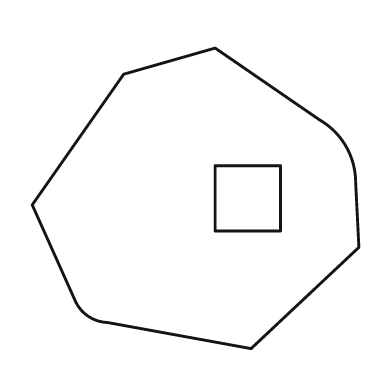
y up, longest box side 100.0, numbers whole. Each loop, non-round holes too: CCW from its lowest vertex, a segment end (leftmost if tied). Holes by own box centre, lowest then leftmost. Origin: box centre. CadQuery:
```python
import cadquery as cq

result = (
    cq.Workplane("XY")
    .moveTo(17.0, -46.0)
    .lineTo(50.0, -15.0)
    .lineTo(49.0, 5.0)
    .threePointArc((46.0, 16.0), (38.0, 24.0))
    .lineTo(6.0, 46.0)
    .lineTo(-22.0, 38.0)
    .lineTo(-50.0, -2.0)
    .lineTo(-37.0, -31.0)
    .threePointArc((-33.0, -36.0), (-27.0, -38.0))
    .close()
    .moveTo(6.0, -10.0)
    .lineTo(26.0, -10.0)
    .lineTo(26.0, 10.0)
    .lineTo(6.0, 10.0)
    .close()
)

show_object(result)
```